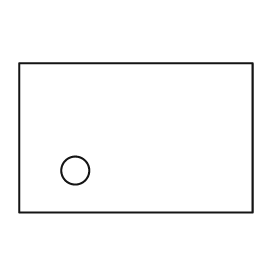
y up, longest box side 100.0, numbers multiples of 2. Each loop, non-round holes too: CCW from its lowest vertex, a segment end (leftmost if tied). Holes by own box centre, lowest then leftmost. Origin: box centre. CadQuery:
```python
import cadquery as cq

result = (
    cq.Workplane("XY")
    .moveTo(-50.0, -32.0)
    .lineTo(50.0, -32.0)
    .lineTo(50.0, 32.0)
    .lineTo(-50.0, 32.0)
    .close()
    .moveTo(-26.0, -14.0)
    .circle(6.0)
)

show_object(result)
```